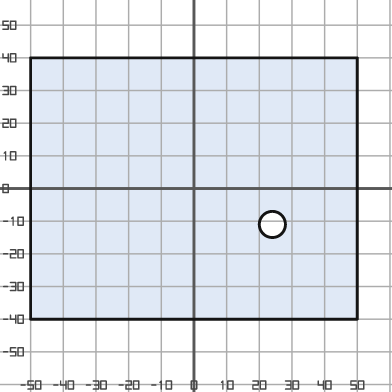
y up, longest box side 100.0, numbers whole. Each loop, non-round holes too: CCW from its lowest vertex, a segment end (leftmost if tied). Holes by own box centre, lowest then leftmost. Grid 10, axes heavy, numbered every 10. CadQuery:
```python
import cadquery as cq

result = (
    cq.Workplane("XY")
    .moveTo(-50.0, -40.0)
    .lineTo(50.0, -40.0)
    .lineTo(50.0, 40.0)
    .lineTo(-50.0, 40.0)
    .close()
    .moveTo(24.0, -11.0)
    .circle(4.0)
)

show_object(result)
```